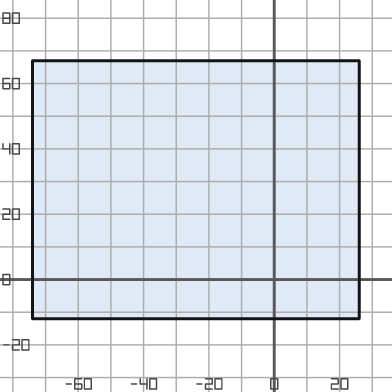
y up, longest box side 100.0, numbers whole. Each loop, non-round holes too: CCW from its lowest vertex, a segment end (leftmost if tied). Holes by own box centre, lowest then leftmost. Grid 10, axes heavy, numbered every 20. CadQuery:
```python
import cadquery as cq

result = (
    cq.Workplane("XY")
    .moveTo(-74.0, -12.0)
    .lineTo(26.0, -12.0)
    .lineTo(26.0, 67.0)
    .lineTo(-74.0, 67.0)
    .close()
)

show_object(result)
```